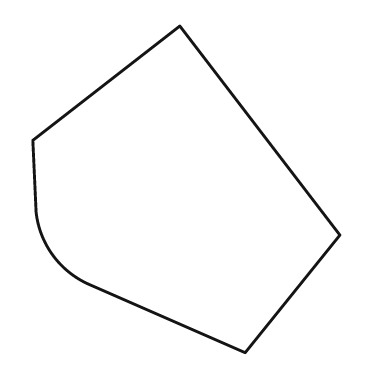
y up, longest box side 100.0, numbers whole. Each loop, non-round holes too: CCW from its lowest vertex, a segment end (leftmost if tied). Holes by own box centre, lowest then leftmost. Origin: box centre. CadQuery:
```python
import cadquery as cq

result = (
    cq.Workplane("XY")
    .moveTo(18.0, -50.0)
    .lineTo(47.0, -14.0)
    .lineTo(-2.0, 50.0)
    .lineTo(-47.0, 15.0)
    .lineTo(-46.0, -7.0)
    .threePointArc((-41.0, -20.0), (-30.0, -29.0))
    .close()
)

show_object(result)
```